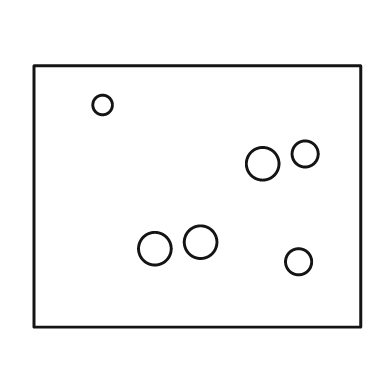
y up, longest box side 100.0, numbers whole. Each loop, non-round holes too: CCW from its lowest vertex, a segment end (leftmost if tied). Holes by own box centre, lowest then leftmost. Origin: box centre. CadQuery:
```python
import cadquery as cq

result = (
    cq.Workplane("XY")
    .moveTo(-50.0, -40.0)
    .lineTo(50.0, -40.0)
    .lineTo(50.0, 40.0)
    .lineTo(-50.0, 40.0)
    .close()
    .moveTo(31.0, -20.0)
    .circle(4.0)
    .moveTo(-13.0, -16.0)
    .circle(5.0)
    .moveTo(1.0, -14.0)
    .circle(5.0)
    .moveTo(20.0, 10.0)
    .circle(5.0)
    .moveTo(33.0, 13.0)
    .circle(4.0)
    .moveTo(-29.0, 28.0)
    .circle(3.0)
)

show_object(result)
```